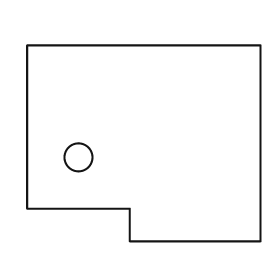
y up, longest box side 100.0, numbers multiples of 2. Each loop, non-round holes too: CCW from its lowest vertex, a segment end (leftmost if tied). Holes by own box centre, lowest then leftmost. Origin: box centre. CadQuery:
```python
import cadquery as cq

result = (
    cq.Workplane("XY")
    .moveTo(-6.0, -42.0)
    .lineTo(50.0, -42.0)
    .lineTo(50.0, 42.0)
    .lineTo(-50.0, 42.0)
    .lineTo(-50.0, -28.0)
    .lineTo(-6.0, -28.0)
    .close()
    .moveTo(-28.0, -6.0)
    .circle(6.0)
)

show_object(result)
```